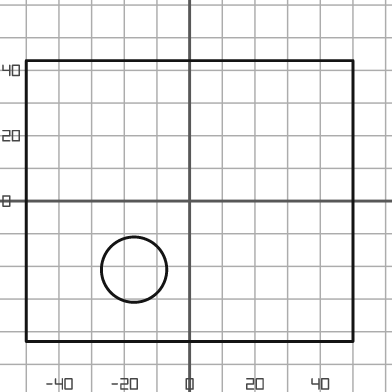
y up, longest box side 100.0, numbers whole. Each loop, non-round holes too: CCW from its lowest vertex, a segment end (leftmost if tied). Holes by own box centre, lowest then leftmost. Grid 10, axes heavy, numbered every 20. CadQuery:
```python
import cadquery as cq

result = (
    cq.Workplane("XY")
    .moveTo(-50.0, -43.0)
    .lineTo(50.0, -43.0)
    .lineTo(50.0, 43.0)
    .lineTo(-50.0, 43.0)
    .close()
    .moveTo(-17.0, -21.0)
    .circle(10.0)
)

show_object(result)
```